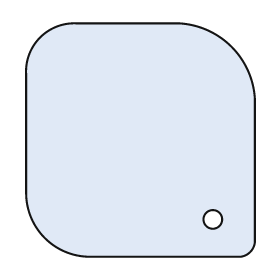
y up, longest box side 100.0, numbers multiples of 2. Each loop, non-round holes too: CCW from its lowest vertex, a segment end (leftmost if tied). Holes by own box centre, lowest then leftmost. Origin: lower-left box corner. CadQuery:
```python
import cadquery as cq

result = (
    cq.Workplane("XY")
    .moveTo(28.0, 0.0)
    .lineTo(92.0, 0.0)
    .threePointArc((96.0, 2.0), (98.0, 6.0))
    .lineTo(98.0, 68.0)
    .threePointArc((88.0, 90.0), (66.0, 100.0))
    .lineTo(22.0, 100.0)
    .threePointArc((6.0, 94.0), (0.0, 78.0))
    .lineTo(0.0, 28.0)
    .threePointArc((8.0, 8.0), (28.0, 0.0))
    .close()
    .moveTo(80.0, 16.0)
    .circle(4.0)
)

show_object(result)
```